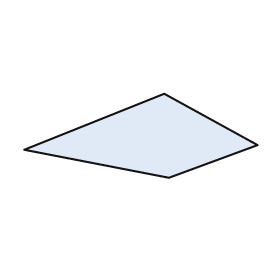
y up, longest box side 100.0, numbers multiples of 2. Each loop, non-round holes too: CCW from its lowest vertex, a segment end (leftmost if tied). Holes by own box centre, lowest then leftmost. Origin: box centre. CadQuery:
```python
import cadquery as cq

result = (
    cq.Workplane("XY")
    .moveTo(12.0, -18.0)
    .lineTo(50.0, -4.0)
    .lineTo(10.0, 18.0)
    .lineTo(-50.0, -6.0)
    .close()
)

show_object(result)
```